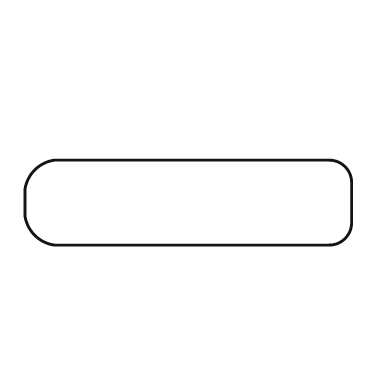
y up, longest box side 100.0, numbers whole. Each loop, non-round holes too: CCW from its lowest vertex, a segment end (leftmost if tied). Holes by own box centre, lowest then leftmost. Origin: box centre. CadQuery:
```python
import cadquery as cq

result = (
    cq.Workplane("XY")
    .moveTo(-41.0, -13.0)
    .lineTo(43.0, -13.0)
    .threePointArc((48.0, -11.0), (50.0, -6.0))
    .lineTo(50.0, 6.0)
    .threePointArc((48.0, 11.0), (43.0, 13.0))
    .lineTo(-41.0, 13.0)
    .threePointArc((-47.0, 10.0), (-50.0, 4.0))
    .lineTo(-50.0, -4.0)
    .threePointArc((-47.0, -10.0), (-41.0, -13.0))
    .close()
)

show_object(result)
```